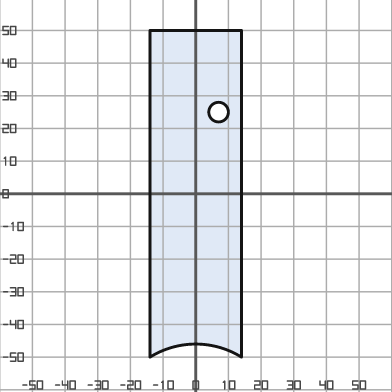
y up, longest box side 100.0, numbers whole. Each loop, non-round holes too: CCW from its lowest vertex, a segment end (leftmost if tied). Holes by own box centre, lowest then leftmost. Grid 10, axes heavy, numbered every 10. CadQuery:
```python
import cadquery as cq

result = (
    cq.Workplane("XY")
    .moveTo(-14.0, -50.0)
    .threePointArc((0.0, -46.0), (14.0, -50.0))
    .lineTo(14.0, 50.0)
    .lineTo(-14.0, 50.0)
    .close()
    .moveTo(7.0, 25.0)
    .circle(3.0)
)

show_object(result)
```